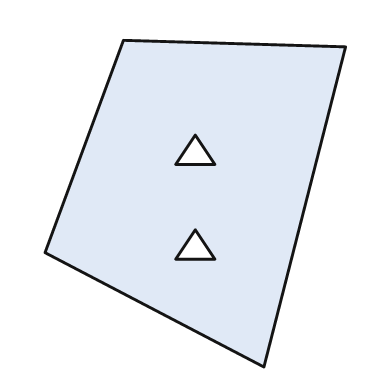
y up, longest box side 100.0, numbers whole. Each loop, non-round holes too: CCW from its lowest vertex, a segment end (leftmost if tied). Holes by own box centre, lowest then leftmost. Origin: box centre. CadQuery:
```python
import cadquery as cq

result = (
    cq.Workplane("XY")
    .moveTo(21.0, -50.0)
    .lineTo(46.0, 48.0)
    .lineTo(-22.0, 50.0)
    .lineTo(-46.0, -15.0)
    .close()
    .moveTo(-6.0, -17.0)
    .lineTo(6.0, -17.0)
    .lineTo(0.0, -8.0)
    .close()
    .moveTo(-6.0, 12.0)
    .lineTo(6.0, 12.0)
    .lineTo(0.0, 21.0)
    .close()
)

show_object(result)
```